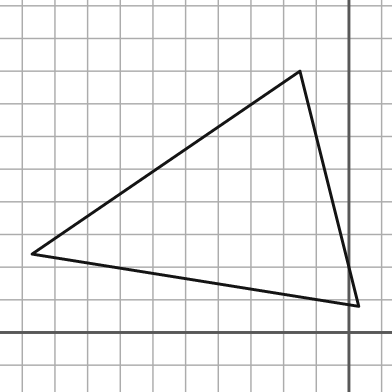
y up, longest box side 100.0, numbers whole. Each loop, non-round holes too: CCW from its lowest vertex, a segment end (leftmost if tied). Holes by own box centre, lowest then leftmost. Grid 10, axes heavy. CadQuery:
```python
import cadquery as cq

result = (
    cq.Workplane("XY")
    .moveTo(3.0, 8.0)
    .lineTo(-15.0, 80.0)
    .lineTo(-97.0, 24.0)
    .close()
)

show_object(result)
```